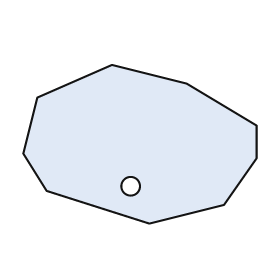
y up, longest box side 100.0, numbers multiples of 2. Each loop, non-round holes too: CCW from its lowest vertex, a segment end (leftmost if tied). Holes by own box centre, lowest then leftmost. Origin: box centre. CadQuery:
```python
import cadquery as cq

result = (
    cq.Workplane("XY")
    .moveTo(4.0, -34.0)
    .lineTo(36.0, -26.0)
    .lineTo(50.0, -6.0)
    .lineTo(50.0, 8.0)
    .lineTo(20.0, 26.0)
    .lineTo(-12.0, 34.0)
    .lineTo(-44.0, 20.0)
    .lineTo(-50.0, -4.0)
    .lineTo(-40.0, -20.0)
    .close()
    .moveTo(-4.0, -18.0)
    .circle(4.0)
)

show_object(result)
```